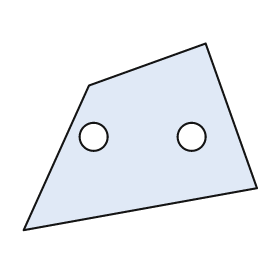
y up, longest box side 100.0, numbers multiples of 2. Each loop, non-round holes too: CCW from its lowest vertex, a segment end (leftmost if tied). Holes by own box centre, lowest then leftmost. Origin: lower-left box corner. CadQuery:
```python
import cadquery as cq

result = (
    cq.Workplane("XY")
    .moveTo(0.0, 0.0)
    .lineTo(100.0, 18.0)
    .lineTo(78.0, 80.0)
    .lineTo(28.0, 62.0)
    .close()
    .moveTo(30.0, 40.0)
    .circle(6.0)
    .moveTo(72.0, 40.0)
    .circle(6.0)
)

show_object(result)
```